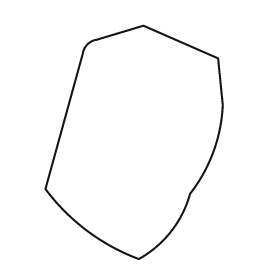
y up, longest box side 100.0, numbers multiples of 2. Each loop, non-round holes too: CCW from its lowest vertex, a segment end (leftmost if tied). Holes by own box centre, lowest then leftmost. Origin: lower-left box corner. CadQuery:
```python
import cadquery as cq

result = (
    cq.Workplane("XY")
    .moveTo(40.0, 0.0)
    .threePointArc((54.0, 12.0), (62.0, 28.0))
    .threePointArc((72.0, 46.0), (76.0, 66.0))
    .lineTo(74.0, 86.0)
    .lineTo(42.0, 100.0)
    .lineTo(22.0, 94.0)
    .threePointArc((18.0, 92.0), (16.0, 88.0))
    .lineTo(0.0, 30.0)
    .threePointArc((18.0, 12.0), (40.0, 0.0))
    .close()
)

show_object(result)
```